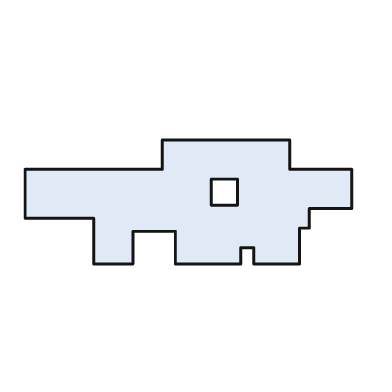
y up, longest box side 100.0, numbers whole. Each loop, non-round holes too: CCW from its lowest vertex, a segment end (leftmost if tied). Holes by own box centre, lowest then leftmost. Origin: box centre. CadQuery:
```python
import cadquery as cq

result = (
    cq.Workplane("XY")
    .moveTo(-29.0, -19.0)
    .lineTo(-17.0, -19.0)
    .lineTo(-17.0, -9.0)
    .lineTo(-4.0, -9.0)
    .lineTo(-4.0, -19.0)
    .lineTo(16.0, -19.0)
    .lineTo(16.0, -14.0)
    .lineTo(20.0, -14.0)
    .lineTo(20.0, -19.0)
    .lineTo(34.0, -19.0)
    .lineTo(34.0, -8.0)
    .lineTo(37.0, -8.0)
    .lineTo(37.0, -2.0)
    .lineTo(50.0, -2.0)
    .lineTo(50.0, 10.0)
    .lineTo(31.0, 10.0)
    .lineTo(31.0, 19.0)
    .lineTo(-8.0, 19.0)
    .lineTo(-8.0, 10.0)
    .lineTo(-50.0, 10.0)
    .lineTo(-50.0, -5.0)
    .lineTo(-29.0, -5.0)
    .close()
    .moveTo(7.0, -1.0)
    .lineTo(15.0, -1.0)
    .lineTo(15.0, 7.0)
    .lineTo(7.0, 7.0)
    .close()
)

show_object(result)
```